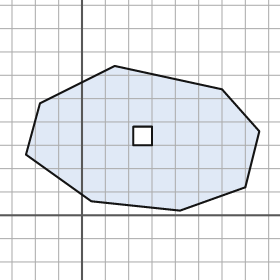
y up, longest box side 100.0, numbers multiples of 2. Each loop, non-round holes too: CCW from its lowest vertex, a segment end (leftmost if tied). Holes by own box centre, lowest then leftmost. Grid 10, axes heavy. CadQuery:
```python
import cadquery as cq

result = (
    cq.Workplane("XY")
    .moveTo(42.0, 2.0)
    .lineTo(70.0, 12.0)
    .lineTo(76.0, 36.0)
    .lineTo(60.0, 54.0)
    .lineTo(14.0, 64.0)
    .lineTo(-18.0, 48.0)
    .lineTo(-24.0, 26.0)
    .lineTo(4.0, 6.0)
    .close()
    .moveTo(22.0, 30.0)
    .lineTo(30.0, 30.0)
    .lineTo(30.0, 38.0)
    .lineTo(22.0, 38.0)
    .close()
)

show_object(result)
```